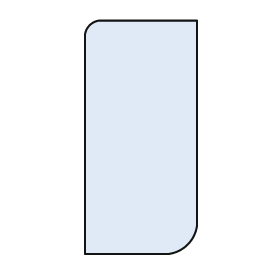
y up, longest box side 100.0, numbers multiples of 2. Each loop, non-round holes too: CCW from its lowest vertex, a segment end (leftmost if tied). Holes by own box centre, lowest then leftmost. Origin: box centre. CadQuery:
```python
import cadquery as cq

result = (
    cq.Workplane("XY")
    .moveTo(-24.0, -50.0)
    .lineTo(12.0, -50.0)
    .threePointArc((20.0, -46.0), (24.0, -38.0))
    .lineTo(24.0, 50.0)
    .lineTo(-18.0, 50.0)
    .threePointArc((-22.0, 48.0), (-24.0, 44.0))
    .close()
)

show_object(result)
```